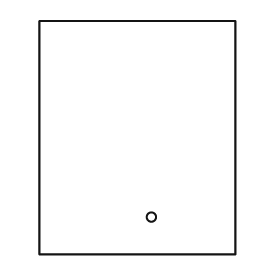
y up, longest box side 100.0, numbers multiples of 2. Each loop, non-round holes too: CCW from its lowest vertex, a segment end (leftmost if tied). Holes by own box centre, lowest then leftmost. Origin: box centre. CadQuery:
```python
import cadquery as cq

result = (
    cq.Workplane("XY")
    .moveTo(-42.0, -50.0)
    .lineTo(42.0, -50.0)
    .lineTo(42.0, 50.0)
    .lineTo(-42.0, 50.0)
    .close()
    .moveTo(6.0, -34.0)
    .circle(2.0)
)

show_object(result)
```